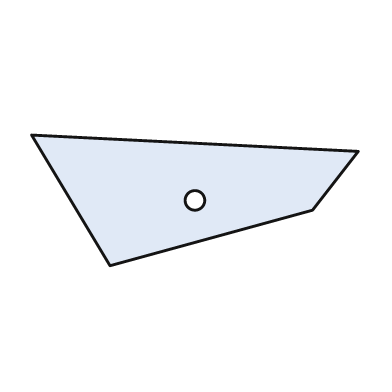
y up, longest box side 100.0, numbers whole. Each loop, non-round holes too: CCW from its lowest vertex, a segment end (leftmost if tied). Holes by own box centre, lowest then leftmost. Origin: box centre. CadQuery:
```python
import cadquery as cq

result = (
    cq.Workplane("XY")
    .moveTo(-26.0, -20.0)
    .lineTo(36.0, -3.0)
    .lineTo(50.0, 15.0)
    .lineTo(-50.0, 20.0)
    .close()
    .moveTo(0.0, 0.0)
    .circle(3.0)
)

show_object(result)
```